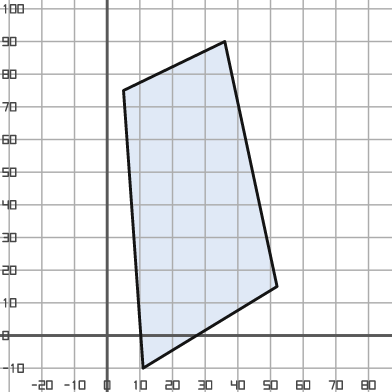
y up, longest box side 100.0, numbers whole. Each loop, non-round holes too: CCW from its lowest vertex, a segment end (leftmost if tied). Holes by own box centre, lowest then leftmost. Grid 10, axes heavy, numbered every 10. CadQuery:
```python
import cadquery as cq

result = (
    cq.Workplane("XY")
    .moveTo(11.0, -10.0)
    .lineTo(52.0, 15.0)
    .lineTo(36.0, 90.0)
    .lineTo(5.0, 75.0)
    .close()
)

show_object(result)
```